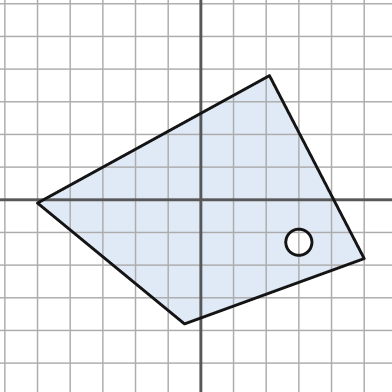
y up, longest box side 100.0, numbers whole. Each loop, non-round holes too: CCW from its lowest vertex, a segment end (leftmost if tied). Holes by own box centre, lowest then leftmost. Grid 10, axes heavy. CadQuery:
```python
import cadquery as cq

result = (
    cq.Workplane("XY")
    .moveTo(-5.0, -38.0)
    .lineTo(50.0, -18.0)
    .lineTo(21.0, 38.0)
    .lineTo(-50.0, -1.0)
    .close()
    .moveTo(30.0, -13.0)
    .circle(4.0)
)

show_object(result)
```